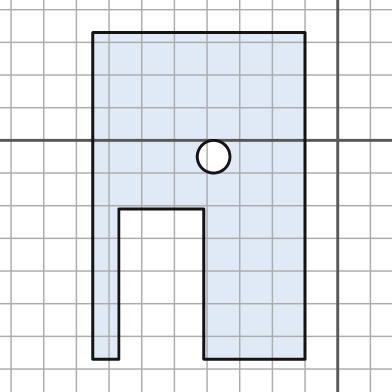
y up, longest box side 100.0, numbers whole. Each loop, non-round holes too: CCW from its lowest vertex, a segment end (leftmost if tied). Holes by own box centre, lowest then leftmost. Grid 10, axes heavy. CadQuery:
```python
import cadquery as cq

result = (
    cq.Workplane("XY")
    .moveTo(-75.0, -67.0)
    .lineTo(-67.0, -67.0)
    .lineTo(-67.0, -21.0)
    .lineTo(-41.0, -21.0)
    .lineTo(-41.0, -67.0)
    .lineTo(-10.0, -67.0)
    .lineTo(-10.0, 33.0)
    .lineTo(-75.0, 33.0)
    .close()
    .moveTo(-38.0, -5.0)
    .circle(5.0)
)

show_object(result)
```